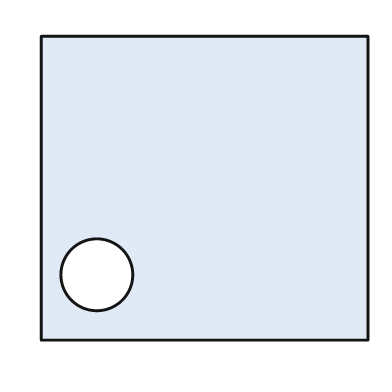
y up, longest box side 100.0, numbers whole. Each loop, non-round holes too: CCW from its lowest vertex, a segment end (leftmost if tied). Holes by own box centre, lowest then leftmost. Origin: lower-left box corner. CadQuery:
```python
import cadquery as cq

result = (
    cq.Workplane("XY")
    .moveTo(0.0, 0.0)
    .lineTo(100.0, 0.0)
    .lineTo(100.0, 93.0)
    .lineTo(0.0, 93.0)
    .close()
    .moveTo(17.0, 20.0)
    .circle(11.0)
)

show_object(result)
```